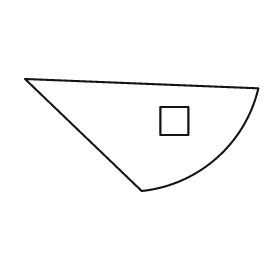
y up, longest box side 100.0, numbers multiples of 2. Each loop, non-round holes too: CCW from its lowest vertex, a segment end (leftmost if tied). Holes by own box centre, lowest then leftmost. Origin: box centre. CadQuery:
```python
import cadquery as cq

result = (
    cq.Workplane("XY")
    .moveTo(0.0, -24.0)
    .threePointArc((32.0, -10.0), (50.0, 20.0))
    .lineTo(-50.0, 24.0)
    .close()
    .moveTo(8.0, 0.0)
    .lineTo(20.0, 0.0)
    .lineTo(20.0, 12.0)
    .lineTo(8.0, 12.0)
    .close()
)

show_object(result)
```